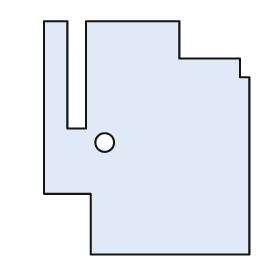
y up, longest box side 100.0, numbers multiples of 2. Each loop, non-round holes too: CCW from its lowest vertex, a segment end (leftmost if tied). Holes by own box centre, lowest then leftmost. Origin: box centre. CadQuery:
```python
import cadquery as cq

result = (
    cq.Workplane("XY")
    .moveTo(-24.0, -50.0)
    .lineTo(44.0, -50.0)
    .lineTo(44.0, 26.0)
    .lineTo(40.0, 26.0)
    .lineTo(40.0, 34.0)
    .lineTo(14.0, 34.0)
    .lineTo(14.0, 50.0)
    .lineTo(-26.0, 50.0)
    .lineTo(-26.0, 4.0)
    .lineTo(-34.0, 4.0)
    .lineTo(-34.0, 50.0)
    .lineTo(-44.0, 50.0)
    .lineTo(-44.0, -24.0)
    .lineTo(-24.0, -24.0)
    .close()
    .moveTo(-18.0, -2.0)
    .circle(4.0)
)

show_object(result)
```